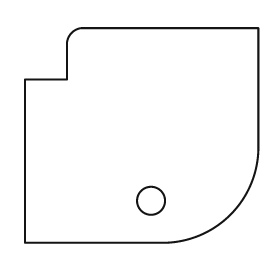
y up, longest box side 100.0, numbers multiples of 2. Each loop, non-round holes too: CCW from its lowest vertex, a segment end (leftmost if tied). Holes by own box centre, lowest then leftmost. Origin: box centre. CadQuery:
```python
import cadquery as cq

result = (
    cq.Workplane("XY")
    .moveTo(-50.0, -46.0)
    .lineTo(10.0, -46.0)
    .threePointArc((38.0, -34.0), (50.0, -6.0))
    .lineTo(50.0, 46.0)
    .lineTo(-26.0, 46.0)
    .threePointArc((-30.0, 44.0), (-32.0, 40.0))
    .lineTo(-32.0, 24.0)
    .lineTo(-50.0, 24.0)
    .close()
    .moveTo(4.0, -28.0)
    .circle(6.0)
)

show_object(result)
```